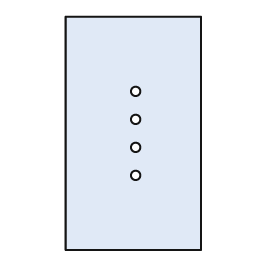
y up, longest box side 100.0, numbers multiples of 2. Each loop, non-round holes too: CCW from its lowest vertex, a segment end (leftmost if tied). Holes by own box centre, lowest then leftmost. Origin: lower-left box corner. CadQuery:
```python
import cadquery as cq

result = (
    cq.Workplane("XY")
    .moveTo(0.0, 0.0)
    .lineTo(58.0, 0.0)
    .lineTo(58.0, 100.0)
    .lineTo(0.0, 100.0)
    .close()
    .moveTo(30.0, 32.0)
    .circle(2.0)
    .moveTo(30.0, 44.0)
    .circle(2.0)
    .moveTo(30.0, 56.0)
    .circle(2.0)
    .moveTo(30.0, 68.0)
    .circle(2.0)
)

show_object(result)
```